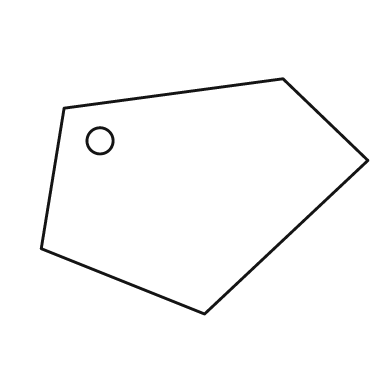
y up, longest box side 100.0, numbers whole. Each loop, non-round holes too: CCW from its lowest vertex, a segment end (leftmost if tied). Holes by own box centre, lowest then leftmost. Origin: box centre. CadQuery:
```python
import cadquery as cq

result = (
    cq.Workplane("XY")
    .moveTo(0.0, -36.0)
    .lineTo(50.0, 11.0)
    .lineTo(24.0, 36.0)
    .lineTo(-43.0, 27.0)
    .lineTo(-50.0, -16.0)
    .close()
    .moveTo(-32.0, 17.0)
    .circle(4.0)
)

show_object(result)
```